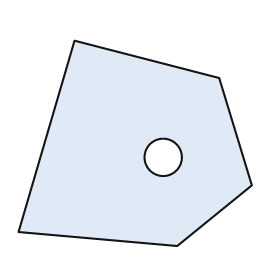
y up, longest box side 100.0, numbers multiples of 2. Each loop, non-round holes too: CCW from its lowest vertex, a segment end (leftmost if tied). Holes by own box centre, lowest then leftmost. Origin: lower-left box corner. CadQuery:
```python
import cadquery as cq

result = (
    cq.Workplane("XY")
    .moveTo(68.0, 0.0)
    .lineTo(100.0, 26.0)
    .lineTo(86.0, 72.0)
    .lineTo(24.0, 88.0)
    .lineTo(0.0, 6.0)
    .close()
    .moveTo(62.0, 38.0)
    .circle(8.0)
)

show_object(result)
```